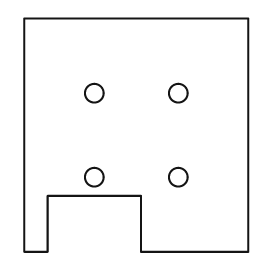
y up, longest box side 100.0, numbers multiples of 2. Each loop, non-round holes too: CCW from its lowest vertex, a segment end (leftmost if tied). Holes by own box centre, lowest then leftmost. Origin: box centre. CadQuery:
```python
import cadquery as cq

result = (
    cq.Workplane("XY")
    .moveTo(-48.0, -50.0)
    .lineTo(-38.0, -50.0)
    .lineTo(-38.0, -26.0)
    .lineTo(2.0, -26.0)
    .lineTo(2.0, -50.0)
    .lineTo(48.0, -50.0)
    .lineTo(48.0, 50.0)
    .lineTo(-48.0, 50.0)
    .close()
    .moveTo(-18.0, -18.0)
    .circle(4.0)
    .moveTo(18.0, -18.0)
    .circle(4.0)
    .moveTo(-18.0, 18.0)
    .circle(4.0)
    .moveTo(18.0, 18.0)
    .circle(4.0)
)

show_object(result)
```